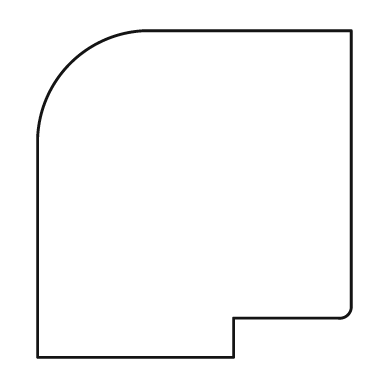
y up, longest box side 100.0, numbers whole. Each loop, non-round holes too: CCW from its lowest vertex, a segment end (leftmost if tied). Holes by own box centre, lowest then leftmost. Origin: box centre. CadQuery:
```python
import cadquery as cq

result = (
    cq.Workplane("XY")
    .moveTo(-48.0, -50.0)
    .lineTo(12.0, -50.0)
    .lineTo(12.0, -38.0)
    .lineTo(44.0, -38.0)
    .threePointArc((47.0, -37.0), (48.0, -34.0))
    .lineTo(48.0, 50.0)
    .lineTo(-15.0, 50.0)
    .threePointArc((-38.0, 40.0), (-48.0, 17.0))
    .close()
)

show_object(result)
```